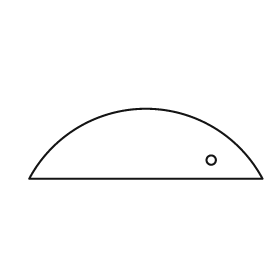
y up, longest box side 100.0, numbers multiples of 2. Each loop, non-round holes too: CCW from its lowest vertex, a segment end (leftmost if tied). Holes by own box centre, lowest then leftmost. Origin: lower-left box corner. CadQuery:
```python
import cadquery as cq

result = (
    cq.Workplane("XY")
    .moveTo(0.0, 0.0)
    .lineTo(100.0, 0.0)
    .threePointArc((50.0, 30.0), (0.0, 0.0))
    .close()
    .moveTo(78.0, 8.0)
    .circle(2.0)
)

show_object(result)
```